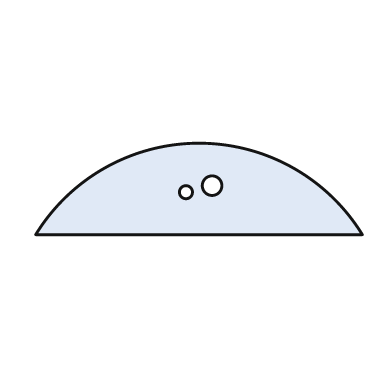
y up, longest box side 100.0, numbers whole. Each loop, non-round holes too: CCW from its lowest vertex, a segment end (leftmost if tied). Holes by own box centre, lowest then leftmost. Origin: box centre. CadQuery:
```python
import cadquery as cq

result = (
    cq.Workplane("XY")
    .moveTo(-50.0, -14.0)
    .lineTo(50.0, -14.0)
    .threePointArc((0.0, 14.0), (-50.0, -14.0))
    .close()
    .moveTo(-4.0, -1.0)
    .circle(2.0)
    .moveTo(4.0, 1.0)
    .circle(3.0)
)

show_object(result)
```